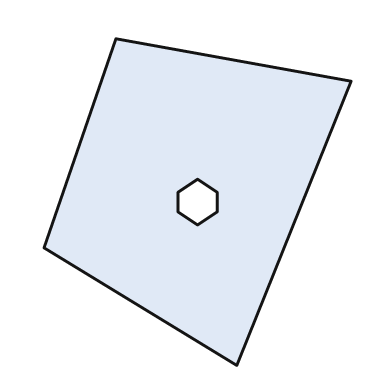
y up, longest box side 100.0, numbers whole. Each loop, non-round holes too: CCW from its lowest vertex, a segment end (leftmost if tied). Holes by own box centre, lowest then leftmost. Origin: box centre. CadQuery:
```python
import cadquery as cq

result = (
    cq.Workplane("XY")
    .moveTo(12.0, -50.0)
    .lineTo(47.0, 37.0)
    .lineTo(-25.0, 50.0)
    .lineTo(-47.0, -14.0)
    .close()
    .moveTo(0.0, -7.0)
    .lineTo(6.0, -3.0)
    .lineTo(6.0, 3.0)
    .lineTo(0.0, 7.0)
    .lineTo(-6.0, 3.0)
    .lineTo(-6.0, -3.0)
    .close()
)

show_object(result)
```